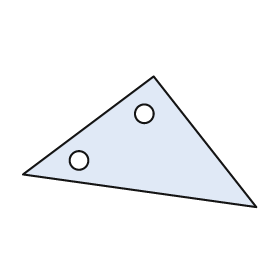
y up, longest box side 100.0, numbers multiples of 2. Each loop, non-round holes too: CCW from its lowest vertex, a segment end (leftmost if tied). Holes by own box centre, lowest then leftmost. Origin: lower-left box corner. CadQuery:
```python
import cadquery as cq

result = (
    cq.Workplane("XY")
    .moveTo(100.0, 0.0)
    .lineTo(56.0, 56.0)
    .lineTo(0.0, 14.0)
    .close()
    .moveTo(24.0, 20.0)
    .circle(4.0)
    .moveTo(52.0, 40.0)
    .circle(4.0)
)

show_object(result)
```